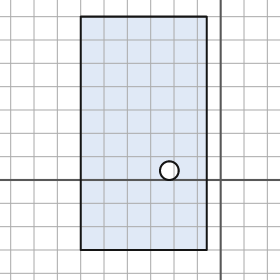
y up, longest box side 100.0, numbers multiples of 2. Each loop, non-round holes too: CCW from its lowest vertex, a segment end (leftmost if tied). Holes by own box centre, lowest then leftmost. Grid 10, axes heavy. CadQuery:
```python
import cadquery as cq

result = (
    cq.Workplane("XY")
    .moveTo(-60.0, -30.0)
    .lineTo(-6.0, -30.0)
    .lineTo(-6.0, 70.0)
    .lineTo(-60.0, 70.0)
    .close()
    .moveTo(-22.0, 4.0)
    .circle(4.0)
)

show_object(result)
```